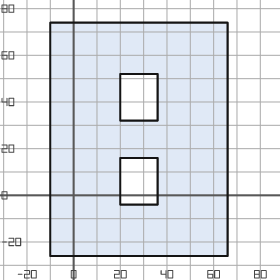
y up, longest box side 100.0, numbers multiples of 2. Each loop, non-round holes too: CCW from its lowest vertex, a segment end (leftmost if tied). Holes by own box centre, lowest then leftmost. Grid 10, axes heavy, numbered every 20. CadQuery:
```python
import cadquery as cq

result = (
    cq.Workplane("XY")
    .moveTo(-10.0, -26.0)
    .lineTo(66.0, -26.0)
    .lineTo(66.0, 74.0)
    .lineTo(-10.0, 74.0)
    .close()
    .moveTo(20.0, -4.0)
    .lineTo(36.0, -4.0)
    .lineTo(36.0, 16.0)
    .lineTo(20.0, 16.0)
    .close()
    .moveTo(20.0, 32.0)
    .lineTo(36.0, 32.0)
    .lineTo(36.0, 52.0)
    .lineTo(20.0, 52.0)
    .close()
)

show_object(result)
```